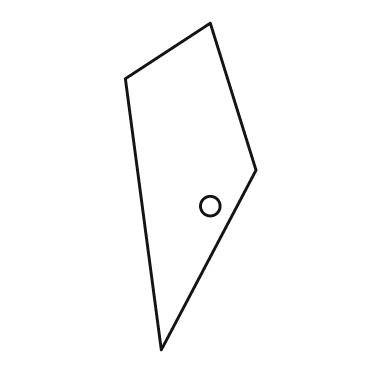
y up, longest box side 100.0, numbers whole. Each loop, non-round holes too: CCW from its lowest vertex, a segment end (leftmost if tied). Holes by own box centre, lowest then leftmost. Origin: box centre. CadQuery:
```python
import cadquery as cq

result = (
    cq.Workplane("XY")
    .moveTo(-9.0, -50.0)
    .lineTo(20.0, 5.0)
    .lineTo(6.0, 50.0)
    .lineTo(-20.0, 33.0)
    .close()
    .moveTo(6.0, -6.0)
    .circle(3.0)
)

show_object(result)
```